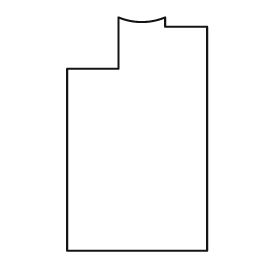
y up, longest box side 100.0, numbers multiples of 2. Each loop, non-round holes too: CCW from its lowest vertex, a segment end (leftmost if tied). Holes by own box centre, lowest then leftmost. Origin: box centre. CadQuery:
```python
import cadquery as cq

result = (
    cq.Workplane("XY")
    .moveTo(-30.0, -50.0)
    .lineTo(30.0, -50.0)
    .lineTo(30.0, 46.0)
    .lineTo(12.0, 46.0)
    .lineTo(12.0, 50.0)
    .threePointArc((2.0, 48.0), (-8.0, 50.0))
    .lineTo(-8.0, 28.0)
    .lineTo(-30.0, 28.0)
    .close()
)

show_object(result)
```